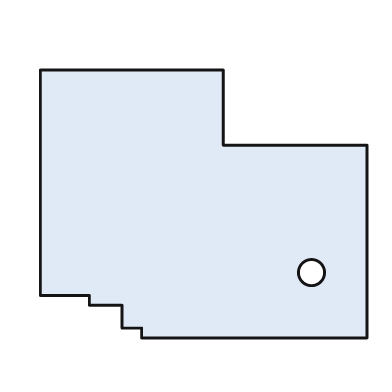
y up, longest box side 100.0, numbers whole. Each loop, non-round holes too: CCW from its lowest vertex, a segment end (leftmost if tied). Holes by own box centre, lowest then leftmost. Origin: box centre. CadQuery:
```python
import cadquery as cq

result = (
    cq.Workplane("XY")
    .moveTo(-19.0, -41.0)
    .lineTo(50.0, -41.0)
    .lineTo(50.0, 18.0)
    .lineTo(6.0, 18.0)
    .lineTo(6.0, 41.0)
    .lineTo(-50.0, 41.0)
    .lineTo(-50.0, -28.0)
    .lineTo(-35.0, -28.0)
    .lineTo(-35.0, -31.0)
    .lineTo(-25.0, -31.0)
    .lineTo(-25.0, -38.0)
    .lineTo(-19.0, -38.0)
    .close()
    .moveTo(33.0, -21.0)
    .circle(4.0)
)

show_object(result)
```